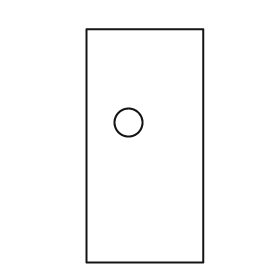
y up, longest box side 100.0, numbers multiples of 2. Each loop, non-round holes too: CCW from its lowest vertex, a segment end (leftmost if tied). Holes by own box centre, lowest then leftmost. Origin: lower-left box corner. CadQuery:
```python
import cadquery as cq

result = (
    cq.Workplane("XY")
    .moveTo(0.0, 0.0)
    .lineTo(50.0, 0.0)
    .lineTo(50.0, 100.0)
    .lineTo(0.0, 100.0)
    .close()
    .moveTo(18.0, 60.0)
    .circle(6.0)
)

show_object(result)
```